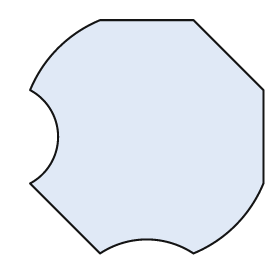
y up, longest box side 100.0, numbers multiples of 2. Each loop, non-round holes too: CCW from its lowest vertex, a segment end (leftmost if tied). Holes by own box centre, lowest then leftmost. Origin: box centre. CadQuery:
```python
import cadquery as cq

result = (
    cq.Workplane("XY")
    .moveTo(-20.0, -50.0)
    .threePointArc((0.0, -44.0), (20.0, -50.0))
    .threePointArc((38.0, -38.0), (50.0, -20.0))
    .lineTo(50.0, 20.0)
    .lineTo(20.0, 50.0)
    .lineTo(-20.0, 50.0)
    .threePointArc((-38.0, 38.0), (-50.0, 20.0))
    .threePointArc((-38.0, 0.0), (-50.0, -20.0))
    .close()
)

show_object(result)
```